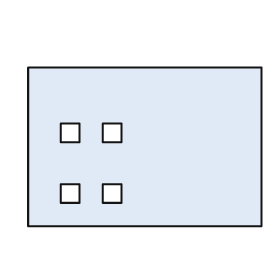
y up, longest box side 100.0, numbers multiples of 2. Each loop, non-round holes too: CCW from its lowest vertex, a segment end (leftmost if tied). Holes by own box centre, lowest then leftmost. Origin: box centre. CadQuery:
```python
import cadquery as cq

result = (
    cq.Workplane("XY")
    .moveTo(-50.0, -34.0)
    .lineTo(50.0, -34.0)
    .lineTo(50.0, 34.0)
    .lineTo(-50.0, 34.0)
    .close()
    .moveTo(-36.0, -24.0)
    .lineTo(-28.0, -24.0)
    .lineTo(-28.0, -16.0)
    .lineTo(-36.0, -16.0)
    .close()
    .moveTo(-18.0, -24.0)
    .lineTo(-10.0, -24.0)
    .lineTo(-10.0, -16.0)
    .lineTo(-18.0, -16.0)
    .close()
    .moveTo(-36.0, 2.0)
    .lineTo(-28.0, 2.0)
    .lineTo(-28.0, 10.0)
    .lineTo(-36.0, 10.0)
    .close()
    .moveTo(-18.0, 2.0)
    .lineTo(-10.0, 2.0)
    .lineTo(-10.0, 10.0)
    .lineTo(-18.0, 10.0)
    .close()
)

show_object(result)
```